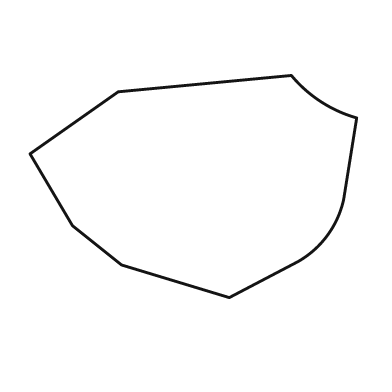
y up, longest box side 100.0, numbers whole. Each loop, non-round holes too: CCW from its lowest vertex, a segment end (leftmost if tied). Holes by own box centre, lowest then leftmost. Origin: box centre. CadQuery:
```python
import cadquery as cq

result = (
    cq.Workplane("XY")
    .moveTo(11.0, -34.0)
    .lineTo(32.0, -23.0)
    .threePointArc((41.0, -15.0), (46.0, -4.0))
    .lineTo(50.0, 21.0)
    .threePointArc((39.0, 26.0), (30.0, 34.0))
    .lineTo(-23.0, 29.0)
    .lineTo(-50.0, 10.0)
    .lineTo(-37.0, -12.0)
    .lineTo(-22.0, -24.0)
    .close()
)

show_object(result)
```